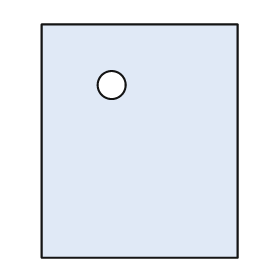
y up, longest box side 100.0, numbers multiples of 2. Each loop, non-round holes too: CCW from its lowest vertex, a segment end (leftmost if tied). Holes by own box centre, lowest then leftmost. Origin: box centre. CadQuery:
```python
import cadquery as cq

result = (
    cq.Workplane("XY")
    .moveTo(-42.0, -50.0)
    .lineTo(42.0, -50.0)
    .lineTo(42.0, 50.0)
    .lineTo(-42.0, 50.0)
    .close()
    .moveTo(-12.0, 24.0)
    .circle(6.0)
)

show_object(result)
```